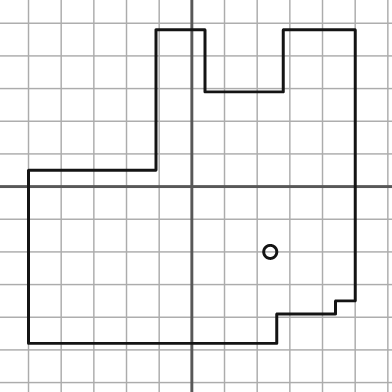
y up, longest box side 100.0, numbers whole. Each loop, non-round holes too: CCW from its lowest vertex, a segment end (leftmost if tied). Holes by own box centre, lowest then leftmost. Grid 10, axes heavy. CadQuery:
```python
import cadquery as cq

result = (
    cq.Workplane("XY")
    .moveTo(-50.0, -48.0)
    .lineTo(26.0, -48.0)
    .lineTo(26.0, -39.0)
    .lineTo(44.0, -39.0)
    .lineTo(44.0, -35.0)
    .lineTo(50.0, -35.0)
    .lineTo(50.0, 48.0)
    .lineTo(28.0, 48.0)
    .lineTo(28.0, 29.0)
    .lineTo(4.0, 29.0)
    .lineTo(4.0, 48.0)
    .lineTo(-11.0, 48.0)
    .lineTo(-11.0, 5.0)
    .lineTo(-50.0, 5.0)
    .close()
    .moveTo(24.0, -20.0)
    .circle(2.0)
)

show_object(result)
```